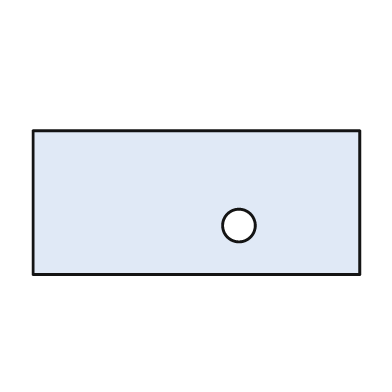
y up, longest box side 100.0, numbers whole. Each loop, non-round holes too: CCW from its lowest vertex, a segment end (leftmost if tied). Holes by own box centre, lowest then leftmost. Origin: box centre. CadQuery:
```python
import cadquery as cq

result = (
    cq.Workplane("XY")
    .moveTo(-50.0, -22.0)
    .lineTo(50.0, -22.0)
    .lineTo(50.0, 22.0)
    .lineTo(-50.0, 22.0)
    .close()
    .moveTo(13.0, -7.0)
    .circle(5.0)
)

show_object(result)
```